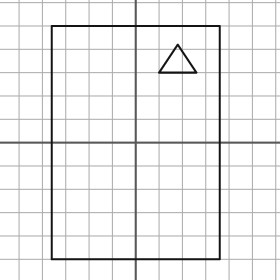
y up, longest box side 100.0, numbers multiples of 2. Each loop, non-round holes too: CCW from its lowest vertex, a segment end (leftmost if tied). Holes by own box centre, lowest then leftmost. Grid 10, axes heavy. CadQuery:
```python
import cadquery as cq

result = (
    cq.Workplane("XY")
    .moveTo(-36.0, -50.0)
    .lineTo(36.0, -50.0)
    .lineTo(36.0, 50.0)
    .lineTo(-36.0, 50.0)
    .close()
    .moveTo(10.0, 30.0)
    .lineTo(26.0, 30.0)
    .lineTo(18.0, 42.0)
    .close()
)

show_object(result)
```